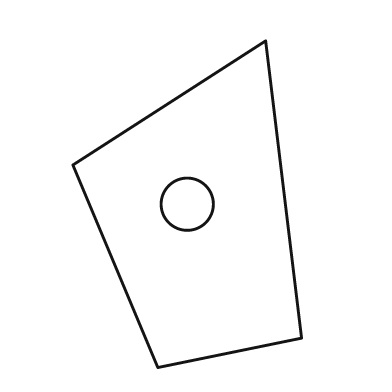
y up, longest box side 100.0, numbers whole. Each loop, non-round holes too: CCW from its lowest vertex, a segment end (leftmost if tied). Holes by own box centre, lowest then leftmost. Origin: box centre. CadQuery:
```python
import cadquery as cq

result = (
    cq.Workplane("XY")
    .moveTo(-9.0, -50.0)
    .lineTo(35.0, -41.0)
    .lineTo(24.0, 50.0)
    .lineTo(-35.0, 12.0)
    .close()
    .moveTo(0.0, 0.0)
    .circle(8.0)
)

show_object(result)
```